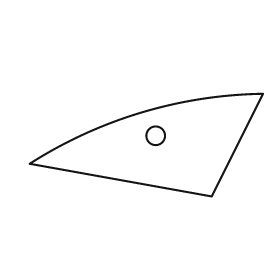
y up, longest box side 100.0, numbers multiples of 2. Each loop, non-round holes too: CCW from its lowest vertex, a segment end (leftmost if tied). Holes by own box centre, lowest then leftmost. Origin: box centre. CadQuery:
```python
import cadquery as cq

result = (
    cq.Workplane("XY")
    .moveTo(28.0, -22.0)
    .lineTo(50.0, 22.0)
    .threePointArc((-2.0, 14.0), (-50.0, -8.0))
    .close()
    .moveTo(4.0, 4.0)
    .circle(4.0)
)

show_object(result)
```